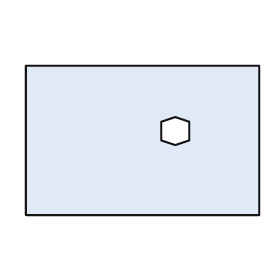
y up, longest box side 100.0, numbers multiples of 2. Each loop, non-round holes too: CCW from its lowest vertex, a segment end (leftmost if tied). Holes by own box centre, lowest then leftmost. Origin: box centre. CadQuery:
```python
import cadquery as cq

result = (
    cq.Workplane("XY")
    .moveTo(-50.0, -32.0)
    .lineTo(50.0, -32.0)
    .lineTo(50.0, 32.0)
    .lineTo(-50.0, 32.0)
    .close()
    .moveTo(14.0, -2.0)
    .lineTo(20.0, 0.0)
    .lineTo(20.0, 8.0)
    .lineTo(14.0, 10.0)
    .lineTo(8.0, 8.0)
    .lineTo(8.0, 0.0)
    .close()
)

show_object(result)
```